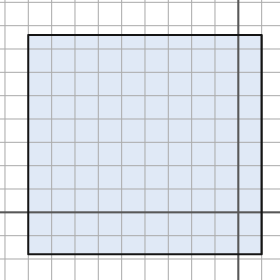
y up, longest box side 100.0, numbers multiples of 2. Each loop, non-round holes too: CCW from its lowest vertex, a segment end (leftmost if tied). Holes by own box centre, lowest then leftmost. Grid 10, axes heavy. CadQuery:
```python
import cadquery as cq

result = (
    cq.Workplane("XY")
    .moveTo(-90.0, -18.0)
    .lineTo(10.0, -18.0)
    .lineTo(10.0, 76.0)
    .lineTo(-90.0, 76.0)
    .close()
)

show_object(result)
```